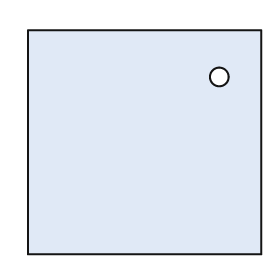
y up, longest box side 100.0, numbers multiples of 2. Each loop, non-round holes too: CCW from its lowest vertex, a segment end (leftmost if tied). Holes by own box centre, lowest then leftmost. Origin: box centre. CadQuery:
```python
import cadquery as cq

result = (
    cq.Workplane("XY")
    .moveTo(-50.0, -48.0)
    .lineTo(50.0, -48.0)
    .lineTo(50.0, 48.0)
    .lineTo(-50.0, 48.0)
    .close()
    .moveTo(32.0, 28.0)
    .circle(4.0)
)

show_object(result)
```